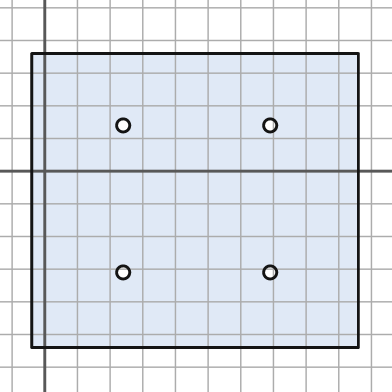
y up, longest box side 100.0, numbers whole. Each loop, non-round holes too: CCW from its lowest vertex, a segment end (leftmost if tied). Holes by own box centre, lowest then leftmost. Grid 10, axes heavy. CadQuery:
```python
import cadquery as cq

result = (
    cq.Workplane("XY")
    .moveTo(-4.0, -54.0)
    .lineTo(96.0, -54.0)
    .lineTo(96.0, 36.0)
    .lineTo(-4.0, 36.0)
    .close()
    .moveTo(24.0, -31.0)
    .circle(2.0)
    .moveTo(69.0, -31.0)
    .circle(2.0)
    .moveTo(24.0, 14.0)
    .circle(2.0)
    .moveTo(69.0, 14.0)
    .circle(2.0)
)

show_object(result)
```